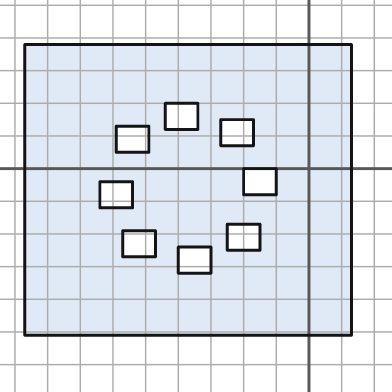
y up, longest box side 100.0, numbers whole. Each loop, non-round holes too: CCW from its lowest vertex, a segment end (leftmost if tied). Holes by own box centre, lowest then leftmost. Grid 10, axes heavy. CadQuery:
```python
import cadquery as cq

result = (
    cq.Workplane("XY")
    .moveTo(-87.0, -51.0)
    .lineTo(13.0, -51.0)
    .lineTo(13.0, 38.0)
    .lineTo(-87.0, 38.0)
    .close()
    .moveTo(-40.0, -32.0)
    .lineTo(-30.0, -32.0)
    .lineTo(-30.0, -24.0)
    .lineTo(-40.0, -24.0)
    .close()
    .moveTo(-57.0, -27.0)
    .lineTo(-47.0, -27.0)
    .lineTo(-47.0, -19.0)
    .lineTo(-57.0, -19.0)
    .close()
    .moveTo(-25.0, -25.0)
    .lineTo(-15.0, -25.0)
    .lineTo(-15.0, -17.0)
    .lineTo(-25.0, -17.0)
    .close()
    .moveTo(-64.0, -12.0)
    .lineTo(-54.0, -12.0)
    .lineTo(-54.0, -4.0)
    .lineTo(-64.0, -4.0)
    .close()
    .moveTo(-20.0, -8.0)
    .lineTo(-10.0, -8.0)
    .lineTo(-10.0, 0.0)
    .lineTo(-20.0, 0.0)
    .close()
    .moveTo(-59.0, 5.0)
    .lineTo(-49.0, 5.0)
    .lineTo(-49.0, 13.0)
    .lineTo(-59.0, 13.0)
    .close()
    .moveTo(-27.0, 7.0)
    .lineTo(-17.0, 7.0)
    .lineTo(-17.0, 15.0)
    .lineTo(-27.0, 15.0)
    .close()
    .moveTo(-44.0, 12.0)
    .lineTo(-34.0, 12.0)
    .lineTo(-34.0, 20.0)
    .lineTo(-44.0, 20.0)
    .close()
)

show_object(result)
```